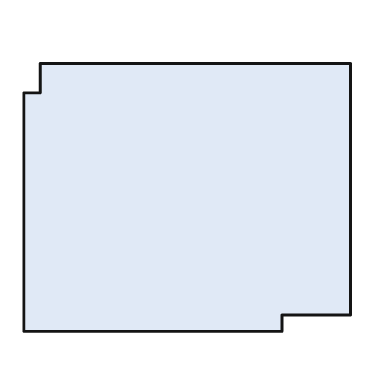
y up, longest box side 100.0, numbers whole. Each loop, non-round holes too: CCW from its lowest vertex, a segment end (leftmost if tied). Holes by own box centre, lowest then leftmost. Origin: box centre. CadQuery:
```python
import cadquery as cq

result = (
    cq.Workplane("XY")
    .moveTo(-50.0, -41.0)
    .lineTo(29.0, -41.0)
    .lineTo(29.0, -36.0)
    .lineTo(50.0, -36.0)
    .lineTo(50.0, 41.0)
    .lineTo(-45.0, 41.0)
    .lineTo(-45.0, 32.0)
    .lineTo(-50.0, 32.0)
    .close()
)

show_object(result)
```